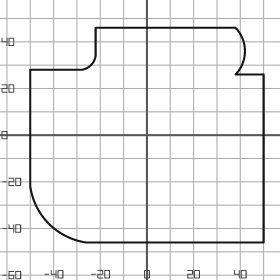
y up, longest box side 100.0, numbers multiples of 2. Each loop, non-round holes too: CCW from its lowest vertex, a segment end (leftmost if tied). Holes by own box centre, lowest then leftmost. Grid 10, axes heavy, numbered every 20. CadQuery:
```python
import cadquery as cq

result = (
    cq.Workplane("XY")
    .moveTo(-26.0, -46.0)
    .lineTo(50.0, -46.0)
    .lineTo(50.0, 26.0)
    .lineTo(38.0, 26.0)
    .threePointArc((42.0, 36.0), (38.0, 46.0))
    .lineTo(-22.0, 46.0)
    .lineTo(-22.0, 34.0)
    .threePointArc((-24.0, 30.0), (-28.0, 28.0))
    .lineTo(-50.0, 28.0)
    .lineTo(-50.0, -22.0)
    .threePointArc((-42.0, -38.0), (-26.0, -46.0))
    .close()
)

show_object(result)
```